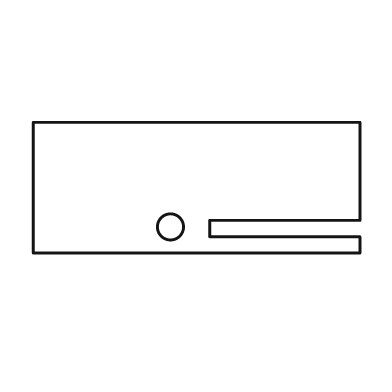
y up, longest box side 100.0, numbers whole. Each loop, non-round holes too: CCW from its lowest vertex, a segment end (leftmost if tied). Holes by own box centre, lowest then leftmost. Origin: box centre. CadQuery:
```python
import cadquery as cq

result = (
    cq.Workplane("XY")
    .moveTo(-50.0, -20.0)
    .lineTo(50.0, -20.0)
    .lineTo(50.0, -15.0)
    .lineTo(4.0, -15.0)
    .lineTo(4.0, -10.0)
    .lineTo(50.0, -10.0)
    .lineTo(50.0, 20.0)
    .lineTo(-50.0, 20.0)
    .close()
    .moveTo(-8.0, -12.0)
    .circle(4.0)
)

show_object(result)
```